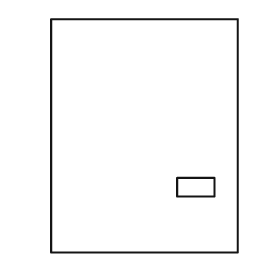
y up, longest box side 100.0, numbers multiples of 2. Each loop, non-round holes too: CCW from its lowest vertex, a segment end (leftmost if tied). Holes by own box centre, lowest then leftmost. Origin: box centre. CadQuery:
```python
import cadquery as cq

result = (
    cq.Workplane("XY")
    .moveTo(-40.0, -50.0)
    .lineTo(40.0, -50.0)
    .lineTo(40.0, 50.0)
    .lineTo(-40.0, 50.0)
    .close()
    .moveTo(14.0, -26.0)
    .lineTo(30.0, -26.0)
    .lineTo(30.0, -18.0)
    .lineTo(14.0, -18.0)
    .close()
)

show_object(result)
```